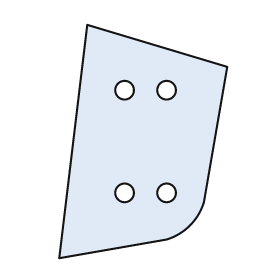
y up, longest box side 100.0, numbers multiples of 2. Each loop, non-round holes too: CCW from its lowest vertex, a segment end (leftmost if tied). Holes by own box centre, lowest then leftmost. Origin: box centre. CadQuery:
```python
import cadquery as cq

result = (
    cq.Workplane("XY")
    .moveTo(-36.0, -50.0)
    .lineTo(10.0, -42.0)
    .threePointArc((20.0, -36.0), (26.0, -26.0))
    .lineTo(36.0, 32.0)
    .lineTo(-24.0, 50.0)
    .close()
    .moveTo(-8.0, -22.0)
    .circle(4.0)
    .moveTo(10.0, -22.0)
    .circle(4.0)
    .moveTo(-8.0, 22.0)
    .circle(4.0)
    .moveTo(10.0, 22.0)
    .circle(4.0)
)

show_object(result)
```